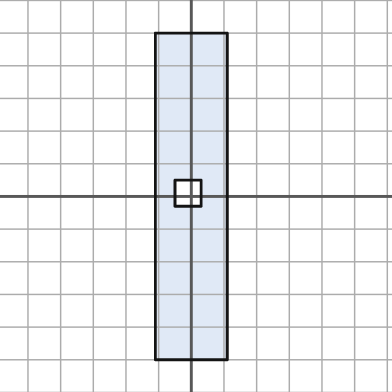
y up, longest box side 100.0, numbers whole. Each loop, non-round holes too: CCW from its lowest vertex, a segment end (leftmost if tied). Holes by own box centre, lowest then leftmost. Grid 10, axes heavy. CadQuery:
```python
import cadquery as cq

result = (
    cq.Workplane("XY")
    .moveTo(-11.0, -50.0)
    .lineTo(11.0, -50.0)
    .lineTo(11.0, 50.0)
    .lineTo(-11.0, 50.0)
    .close()
    .moveTo(-5.0, -3.0)
    .lineTo(3.0, -3.0)
    .lineTo(3.0, 5.0)
    .lineTo(-5.0, 5.0)
    .close()
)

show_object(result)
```